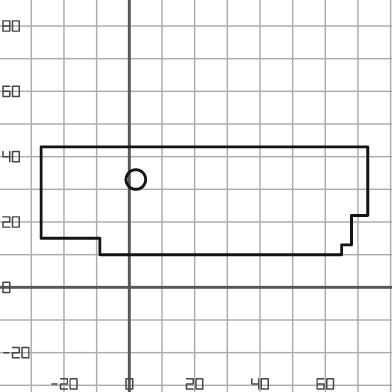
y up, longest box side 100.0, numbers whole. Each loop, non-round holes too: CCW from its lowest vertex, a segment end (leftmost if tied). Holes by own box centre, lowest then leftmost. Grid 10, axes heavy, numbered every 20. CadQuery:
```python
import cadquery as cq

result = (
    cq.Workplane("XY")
    .moveTo(-9.0, 10.0)
    .lineTo(65.0, 10.0)
    .lineTo(65.0, 13.0)
    .lineTo(68.0, 13.0)
    .lineTo(68.0, 22.0)
    .lineTo(73.0, 22.0)
    .lineTo(73.0, 43.0)
    .lineTo(-27.0, 43.0)
    .lineTo(-27.0, 15.0)
    .lineTo(-9.0, 15.0)
    .close()
    .moveTo(2.0, 33.0)
    .circle(3.0)
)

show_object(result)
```